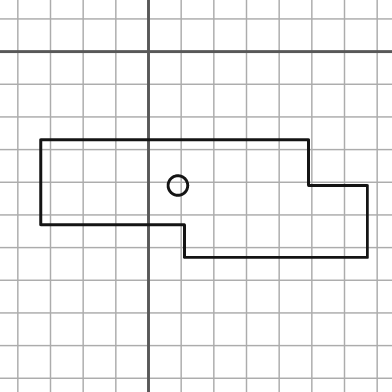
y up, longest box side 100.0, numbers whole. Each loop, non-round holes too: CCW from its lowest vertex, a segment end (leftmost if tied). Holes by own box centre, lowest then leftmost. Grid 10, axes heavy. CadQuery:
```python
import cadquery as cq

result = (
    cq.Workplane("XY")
    .moveTo(11.0, -63.0)
    .lineTo(67.0, -63.0)
    .lineTo(67.0, -41.0)
    .lineTo(49.0, -41.0)
    .lineTo(49.0, -27.0)
    .lineTo(-33.0, -27.0)
    .lineTo(-33.0, -53.0)
    .lineTo(11.0, -53.0)
    .close()
    .moveTo(9.0, -41.0)
    .circle(3.0)
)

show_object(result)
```